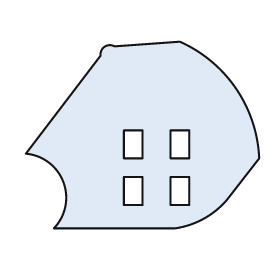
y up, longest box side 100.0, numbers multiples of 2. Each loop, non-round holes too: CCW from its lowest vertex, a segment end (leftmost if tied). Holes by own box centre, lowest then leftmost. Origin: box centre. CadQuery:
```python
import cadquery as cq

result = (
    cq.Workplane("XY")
    .moveTo(-38.0, -40.0)
    .lineTo(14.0, -40.0)
    .threePointArc((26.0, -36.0), (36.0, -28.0))
    .lineTo(50.0, -10.0)
    .threePointArc((40.0, 20.0), (16.0, 40.0))
    .lineTo(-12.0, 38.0)
    .threePointArc((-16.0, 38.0), (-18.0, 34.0))
    .lineTo(-50.0, -8.0)
    .threePointArc((-34.0, -20.0), (-38.0, -40.0))
    .close()
    .moveTo(-8.0, -30.0)
    .lineTo(0.0, -30.0)
    .lineTo(0.0, -18.0)
    .lineTo(-8.0, -18.0)
    .close()
    .moveTo(12.0, -30.0)
    .lineTo(20.0, -30.0)
    .lineTo(20.0, -18.0)
    .lineTo(12.0, -18.0)
    .close()
    .moveTo(-8.0, -10.0)
    .lineTo(0.0, -10.0)
    .lineTo(0.0, 2.0)
    .lineTo(-8.0, 2.0)
    .close()
    .moveTo(12.0, -10.0)
    .lineTo(20.0, -10.0)
    .lineTo(20.0, 2.0)
    .lineTo(12.0, 2.0)
    .close()
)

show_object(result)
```